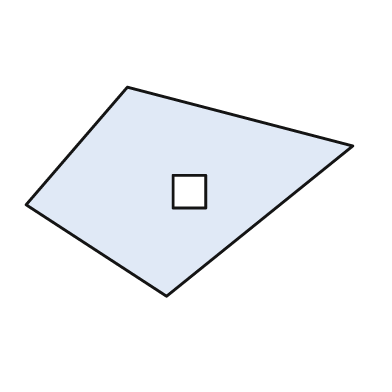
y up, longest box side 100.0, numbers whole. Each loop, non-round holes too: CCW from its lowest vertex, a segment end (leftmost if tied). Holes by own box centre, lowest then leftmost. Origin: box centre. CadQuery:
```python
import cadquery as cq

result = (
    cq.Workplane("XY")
    .moveTo(-7.0, -32.0)
    .lineTo(50.0, 14.0)
    .lineTo(-19.0, 32.0)
    .lineTo(-50.0, -4.0)
    .close()
    .moveTo(-5.0, -5.0)
    .lineTo(5.0, -5.0)
    .lineTo(5.0, 5.0)
    .lineTo(-5.0, 5.0)
    .close()
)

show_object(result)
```